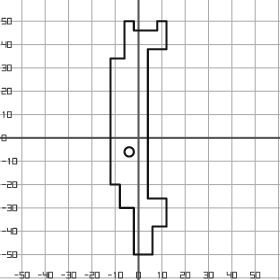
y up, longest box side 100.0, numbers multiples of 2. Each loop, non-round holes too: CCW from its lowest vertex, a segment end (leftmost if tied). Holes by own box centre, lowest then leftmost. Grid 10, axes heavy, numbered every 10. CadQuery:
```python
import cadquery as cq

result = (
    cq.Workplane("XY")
    .moveTo(-2.0, -50.0)
    .lineTo(6.0, -50.0)
    .lineTo(6.0, -38.0)
    .lineTo(12.0, -38.0)
    .lineTo(12.0, -26.0)
    .lineTo(4.0, -26.0)
    .lineTo(4.0, 38.0)
    .lineTo(12.0, 38.0)
    .lineTo(12.0, 50.0)
    .lineTo(8.0, 50.0)
    .lineTo(8.0, 46.0)
    .lineTo(-2.0, 46.0)
    .lineTo(-2.0, 50.0)
    .lineTo(-6.0, 50.0)
    .lineTo(-6.0, 34.0)
    .lineTo(-12.0, 34.0)
    .lineTo(-12.0, -20.0)
    .lineTo(-8.0, -20.0)
    .lineTo(-8.0, -30.0)
    .lineTo(-2.0, -30.0)
    .close()
    .moveTo(-4.0, -6.0)
    .circle(2.0)
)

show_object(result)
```